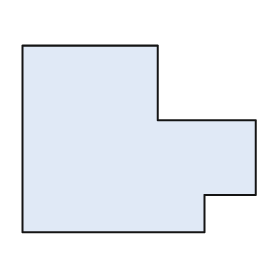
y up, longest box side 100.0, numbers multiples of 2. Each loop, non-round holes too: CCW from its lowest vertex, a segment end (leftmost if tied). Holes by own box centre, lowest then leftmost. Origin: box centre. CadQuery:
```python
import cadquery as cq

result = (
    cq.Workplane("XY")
    .moveTo(-50.0, -40.0)
    .lineTo(28.0, -40.0)
    .lineTo(28.0, -24.0)
    .lineTo(50.0, -24.0)
    .lineTo(50.0, 8.0)
    .lineTo(8.0, 8.0)
    .lineTo(8.0, 40.0)
    .lineTo(-50.0, 40.0)
    .close()
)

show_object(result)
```